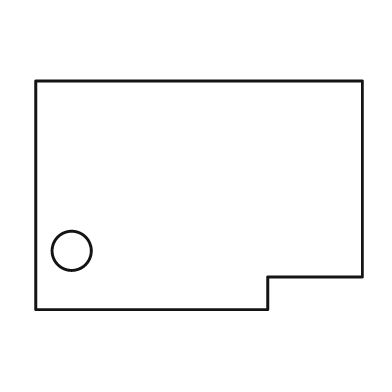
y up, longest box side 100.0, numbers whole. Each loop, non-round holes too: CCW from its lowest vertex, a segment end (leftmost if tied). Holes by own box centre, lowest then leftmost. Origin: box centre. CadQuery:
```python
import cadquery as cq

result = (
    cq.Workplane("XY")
    .moveTo(-50.0, -35.0)
    .lineTo(21.0, -35.0)
    .lineTo(21.0, -25.0)
    .lineTo(50.0, -25.0)
    .lineTo(50.0, 35.0)
    .lineTo(-50.0, 35.0)
    .close()
    .moveTo(-39.0, -17.0)
    .circle(6.0)
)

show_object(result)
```